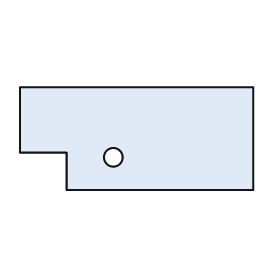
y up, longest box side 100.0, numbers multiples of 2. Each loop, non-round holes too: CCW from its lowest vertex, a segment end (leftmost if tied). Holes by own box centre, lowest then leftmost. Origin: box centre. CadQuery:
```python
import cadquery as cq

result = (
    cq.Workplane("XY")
    .moveTo(-30.0, -22.0)
    .lineTo(50.0, -22.0)
    .lineTo(50.0, 22.0)
    .lineTo(-50.0, 22.0)
    .lineTo(-50.0, -6.0)
    .lineTo(-30.0, -6.0)
    .close()
    .moveTo(-10.0, -8.0)
    .circle(4.0)
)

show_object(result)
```